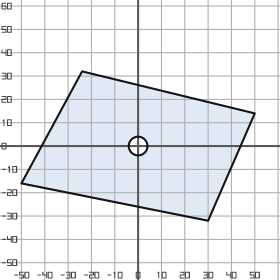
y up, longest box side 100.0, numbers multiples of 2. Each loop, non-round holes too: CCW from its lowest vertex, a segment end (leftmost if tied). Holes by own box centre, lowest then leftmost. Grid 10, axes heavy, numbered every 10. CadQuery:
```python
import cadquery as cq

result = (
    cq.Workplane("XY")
    .moveTo(30.0, -32.0)
    .lineTo(50.0, 14.0)
    .lineTo(-24.0, 32.0)
    .lineTo(-50.0, -16.0)
    .close()
    .moveTo(0.0, 0.0)
    .circle(4.0)
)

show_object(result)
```